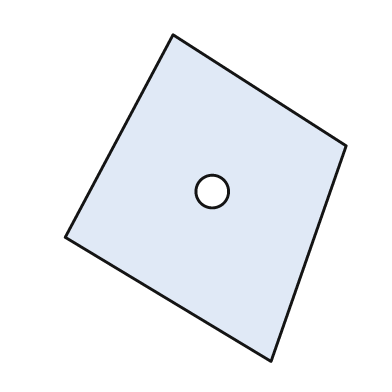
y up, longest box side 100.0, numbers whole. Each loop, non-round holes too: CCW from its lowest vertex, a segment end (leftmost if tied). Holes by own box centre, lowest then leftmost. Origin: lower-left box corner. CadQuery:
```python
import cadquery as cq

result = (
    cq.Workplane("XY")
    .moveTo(63.0, 0.0)
    .lineTo(86.0, 66.0)
    .lineTo(33.0, 100.0)
    .lineTo(0.0, 38.0)
    .close()
    .moveTo(45.0, 52.0)
    .circle(5.0)
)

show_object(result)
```